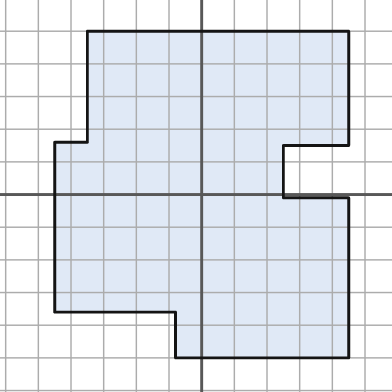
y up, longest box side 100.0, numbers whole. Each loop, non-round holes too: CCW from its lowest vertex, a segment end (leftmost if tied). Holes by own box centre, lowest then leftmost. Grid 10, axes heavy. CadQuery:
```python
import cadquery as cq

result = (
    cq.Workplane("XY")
    .moveTo(-8.0, -50.0)
    .lineTo(45.0, -50.0)
    .lineTo(45.0, -1.0)
    .lineTo(25.0, -1.0)
    .lineTo(25.0, 15.0)
    .lineTo(45.0, 15.0)
    .lineTo(45.0, 50.0)
    .lineTo(-35.0, 50.0)
    .lineTo(-35.0, 16.0)
    .lineTo(-45.0, 16.0)
    .lineTo(-45.0, -36.0)
    .lineTo(-8.0, -36.0)
    .close()
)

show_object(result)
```